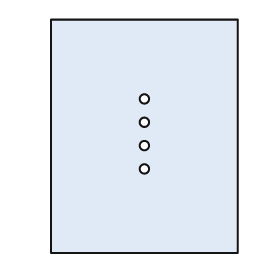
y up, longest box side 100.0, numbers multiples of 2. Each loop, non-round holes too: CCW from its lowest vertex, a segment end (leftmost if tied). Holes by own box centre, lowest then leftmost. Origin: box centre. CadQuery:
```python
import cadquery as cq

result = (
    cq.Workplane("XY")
    .moveTo(-40.0, -50.0)
    .lineTo(40.0, -50.0)
    .lineTo(40.0, 50.0)
    .lineTo(-40.0, 50.0)
    .close()
    .moveTo(0.0, -14.0)
    .circle(2.0)
    .moveTo(0.0, -4.0)
    .circle(2.0)
    .moveTo(0.0, 6.0)
    .circle(2.0)
    .moveTo(0.0, 16.0)
    .circle(2.0)
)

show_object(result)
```